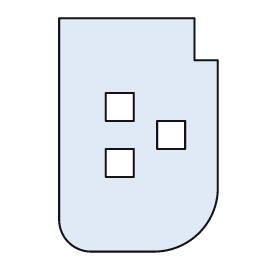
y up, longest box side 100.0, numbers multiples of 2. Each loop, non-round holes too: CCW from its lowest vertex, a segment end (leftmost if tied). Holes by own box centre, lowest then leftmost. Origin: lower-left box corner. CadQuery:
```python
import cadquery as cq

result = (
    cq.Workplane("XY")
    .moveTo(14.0, 0.0)
    .lineTo(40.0, 0.0)
    .threePointArc((60.0, 8.0), (68.0, 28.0))
    .lineTo(68.0, 82.0)
    .lineTo(58.0, 82.0)
    .lineTo(58.0, 100.0)
    .lineTo(0.0, 100.0)
    .lineTo(0.0, 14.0)
    .threePointArc((4.0, 4.0), (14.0, 0.0))
    .close()
    .moveTo(20.0, 32.0)
    .lineTo(32.0, 32.0)
    .lineTo(32.0, 44.0)
    .lineTo(20.0, 44.0)
    .close()
    .moveTo(42.0, 44.0)
    .lineTo(54.0, 44.0)
    .lineTo(54.0, 56.0)
    .lineTo(42.0, 56.0)
    .close()
    .moveTo(20.0, 56.0)
    .lineTo(32.0, 56.0)
    .lineTo(32.0, 68.0)
    .lineTo(20.0, 68.0)
    .close()
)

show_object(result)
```